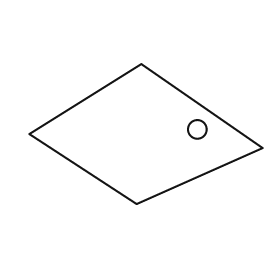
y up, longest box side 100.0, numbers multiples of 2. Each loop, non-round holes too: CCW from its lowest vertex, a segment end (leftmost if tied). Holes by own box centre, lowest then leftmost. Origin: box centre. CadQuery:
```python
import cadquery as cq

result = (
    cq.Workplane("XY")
    .moveTo(-4.0, -30.0)
    .lineTo(50.0, -6.0)
    .lineTo(-2.0, 30.0)
    .lineTo(-50.0, 0.0)
    .close()
    .moveTo(22.0, 2.0)
    .circle(4.0)
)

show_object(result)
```